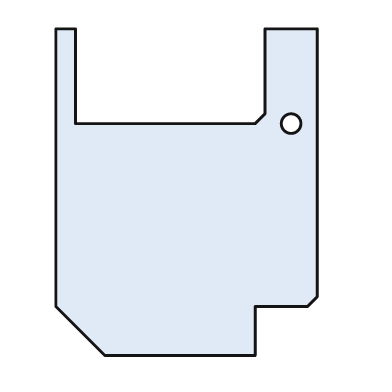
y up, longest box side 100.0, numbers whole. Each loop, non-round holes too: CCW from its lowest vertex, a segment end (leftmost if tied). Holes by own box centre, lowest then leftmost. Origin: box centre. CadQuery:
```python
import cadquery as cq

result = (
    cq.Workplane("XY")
    .moveTo(-25.0, -50.0)
    .lineTo(21.0, -50.0)
    .lineTo(21.0, -35.0)
    .lineTo(37.0, -35.0)
    .lineTo(40.0, -32.0)
    .lineTo(40.0, 50.0)
    .lineTo(24.0, 50.0)
    .lineTo(24.0, 24.0)
    .lineTo(21.0, 21.0)
    .lineTo(-34.0, 21.0)
    .lineTo(-34.0, 50.0)
    .lineTo(-40.0, 50.0)
    .lineTo(-40.0, -35.0)
    .close()
    .moveTo(32.0, 21.0)
    .circle(3.0)
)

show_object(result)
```